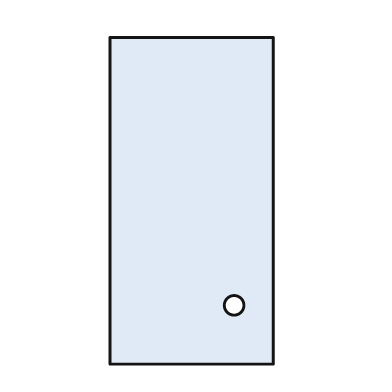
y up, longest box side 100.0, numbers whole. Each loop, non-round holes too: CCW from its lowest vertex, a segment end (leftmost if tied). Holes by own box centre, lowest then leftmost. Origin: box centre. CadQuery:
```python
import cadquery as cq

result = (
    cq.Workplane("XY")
    .moveTo(-25.0, -50.0)
    .lineTo(25.0, -50.0)
    .lineTo(25.0, 50.0)
    .lineTo(-25.0, 50.0)
    .close()
    .moveTo(13.0, -32.0)
    .circle(3.0)
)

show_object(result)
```